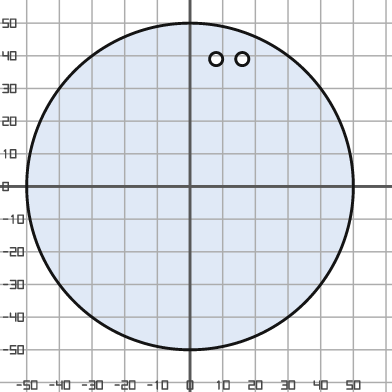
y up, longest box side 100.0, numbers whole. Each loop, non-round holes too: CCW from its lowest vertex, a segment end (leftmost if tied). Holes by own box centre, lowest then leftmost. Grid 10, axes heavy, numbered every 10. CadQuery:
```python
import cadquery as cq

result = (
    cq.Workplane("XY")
    .moveTo(0.0, 0.0)
    .circle(50.0)
    .moveTo(8.0, 39.0)
    .circle(2.0)
    .moveTo(16.0, 39.0)
    .circle(2.0)
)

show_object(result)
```